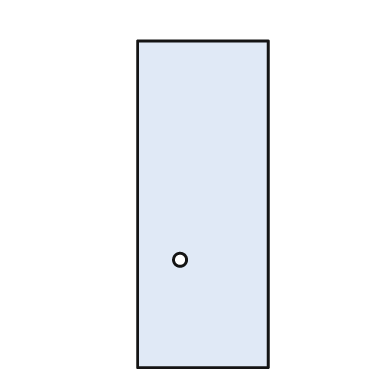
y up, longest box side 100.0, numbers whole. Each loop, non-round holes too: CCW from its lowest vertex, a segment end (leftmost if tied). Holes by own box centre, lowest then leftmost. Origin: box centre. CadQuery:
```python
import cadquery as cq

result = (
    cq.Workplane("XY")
    .moveTo(-20.0, -50.0)
    .lineTo(20.0, -50.0)
    .lineTo(20.0, 50.0)
    .lineTo(-20.0, 50.0)
    .close()
    .moveTo(-7.0, -17.0)
    .circle(2.0)
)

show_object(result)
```